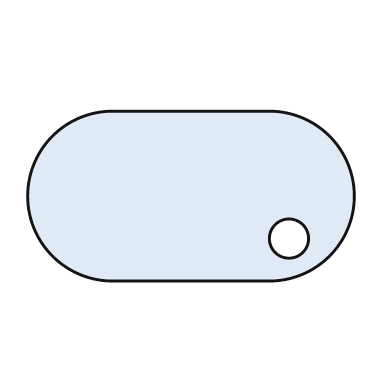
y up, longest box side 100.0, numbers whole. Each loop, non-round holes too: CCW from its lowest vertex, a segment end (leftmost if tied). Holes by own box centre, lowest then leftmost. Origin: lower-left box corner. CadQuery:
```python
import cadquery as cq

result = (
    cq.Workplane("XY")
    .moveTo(26.0, 0.0)
    .lineTo(74.0, 0.0)
    .threePointArc((100.0, 26.0), (74.0, 52.0))
    .lineTo(26.0, 52.0)
    .threePointArc((0.0, 26.0), (26.0, 0.0))
    .close()
    .moveTo(80.0, 13.0)
    .circle(6.0)
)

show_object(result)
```